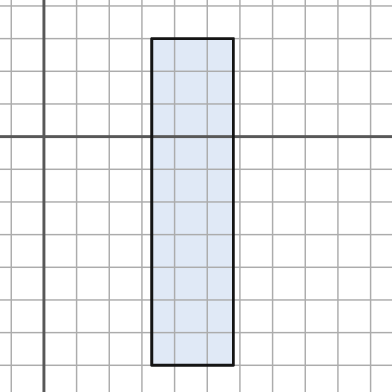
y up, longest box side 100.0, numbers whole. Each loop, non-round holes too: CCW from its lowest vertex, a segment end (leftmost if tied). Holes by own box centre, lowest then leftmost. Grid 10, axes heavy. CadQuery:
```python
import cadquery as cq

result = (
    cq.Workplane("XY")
    .moveTo(33.0, -70.0)
    .lineTo(58.0, -70.0)
    .lineTo(58.0, 30.0)
    .lineTo(33.0, 30.0)
    .close()
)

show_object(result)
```